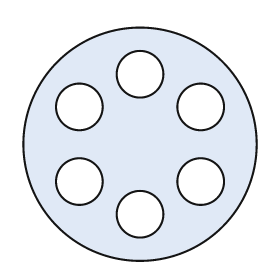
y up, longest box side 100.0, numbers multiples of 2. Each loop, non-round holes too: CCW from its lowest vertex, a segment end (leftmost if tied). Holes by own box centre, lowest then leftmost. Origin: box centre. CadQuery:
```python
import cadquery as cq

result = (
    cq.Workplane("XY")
    .moveTo(0.0, 0.0)
    .circle(50.0)
    .moveTo(0.0, -30.0)
    .circle(10.0)
    .moveTo(-26.0, -16.0)
    .circle(10.0)
    .moveTo(26.0, -16.0)
    .circle(10.0)
    .moveTo(-26.0, 16.0)
    .circle(10.0)
    .moveTo(26.0, 16.0)
    .circle(10.0)
    .moveTo(0.0, 30.0)
    .circle(10.0)
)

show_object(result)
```